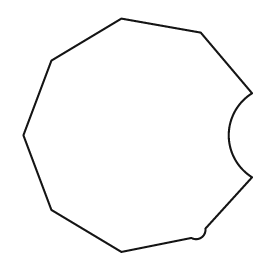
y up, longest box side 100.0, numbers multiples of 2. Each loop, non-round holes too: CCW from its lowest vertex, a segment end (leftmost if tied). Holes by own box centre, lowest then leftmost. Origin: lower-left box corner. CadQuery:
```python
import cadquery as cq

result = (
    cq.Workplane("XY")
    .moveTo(42.0, 0.0)
    .lineTo(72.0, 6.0)
    .threePointArc((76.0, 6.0), (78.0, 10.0))
    .lineTo(98.0, 32.0)
    .threePointArc((88.0, 50.0), (98.0, 68.0))
    .lineTo(76.0, 94.0)
    .lineTo(42.0, 100.0)
    .lineTo(12.0, 82.0)
    .lineTo(0.0, 50.0)
    .lineTo(12.0, 18.0)
    .close()
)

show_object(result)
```